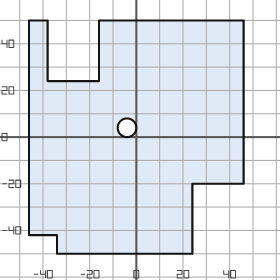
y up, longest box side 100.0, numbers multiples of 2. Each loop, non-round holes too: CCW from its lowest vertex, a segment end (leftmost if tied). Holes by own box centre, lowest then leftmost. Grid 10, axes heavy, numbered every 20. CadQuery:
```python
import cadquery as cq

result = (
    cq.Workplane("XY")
    .moveTo(-34.0, -50.0)
    .lineTo(24.0, -50.0)
    .lineTo(24.0, -20.0)
    .lineTo(46.0, -20.0)
    .lineTo(46.0, 50.0)
    .lineTo(-16.0, 50.0)
    .lineTo(-16.0, 24.0)
    .lineTo(-38.0, 24.0)
    .lineTo(-38.0, 50.0)
    .lineTo(-46.0, 50.0)
    .lineTo(-46.0, -42.0)
    .lineTo(-34.0, -42.0)
    .close()
    .moveTo(-4.0, 4.0)
    .circle(4.0)
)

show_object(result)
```